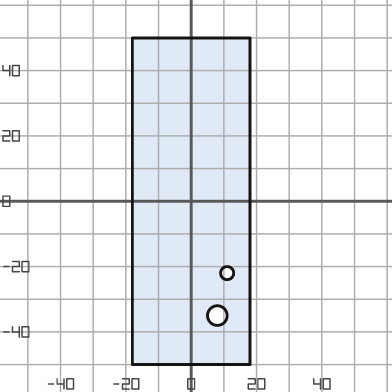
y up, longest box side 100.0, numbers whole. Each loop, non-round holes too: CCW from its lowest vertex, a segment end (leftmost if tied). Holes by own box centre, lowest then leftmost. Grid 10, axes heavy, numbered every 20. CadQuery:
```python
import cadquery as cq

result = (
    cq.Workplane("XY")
    .moveTo(-18.0, -50.0)
    .lineTo(18.0, -50.0)
    .lineTo(18.0, 50.0)
    .lineTo(-18.0, 50.0)
    .close()
    .moveTo(8.0, -35.0)
    .circle(3.0)
    .moveTo(11.0, -22.0)
    .circle(2.0)
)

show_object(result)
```